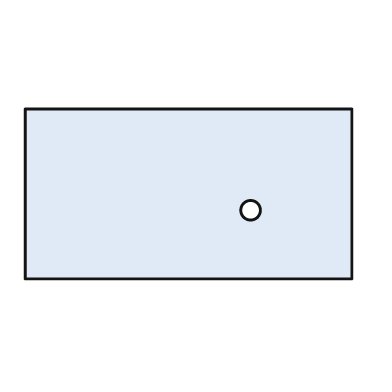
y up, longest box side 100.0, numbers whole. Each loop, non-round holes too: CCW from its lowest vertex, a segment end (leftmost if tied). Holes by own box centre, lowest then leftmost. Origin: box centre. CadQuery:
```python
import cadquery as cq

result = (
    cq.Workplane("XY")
    .moveTo(-50.0, -26.0)
    .lineTo(50.0, -26.0)
    .lineTo(50.0, 26.0)
    .lineTo(-50.0, 26.0)
    .close()
    .moveTo(19.0, -5.0)
    .circle(3.0)
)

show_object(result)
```